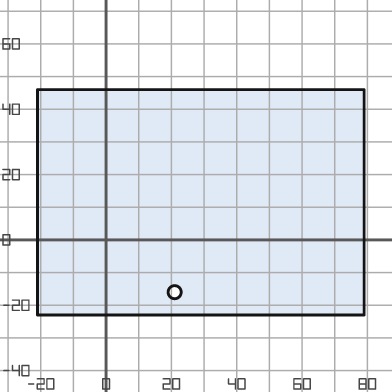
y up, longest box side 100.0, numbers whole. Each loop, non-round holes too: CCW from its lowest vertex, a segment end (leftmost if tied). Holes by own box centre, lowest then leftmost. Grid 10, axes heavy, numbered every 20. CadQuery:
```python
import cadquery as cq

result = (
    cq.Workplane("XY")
    .moveTo(-21.0, -23.0)
    .lineTo(79.0, -23.0)
    .lineTo(79.0, 46.0)
    .lineTo(-21.0, 46.0)
    .close()
    .moveTo(21.0, -16.0)
    .circle(2.0)
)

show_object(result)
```